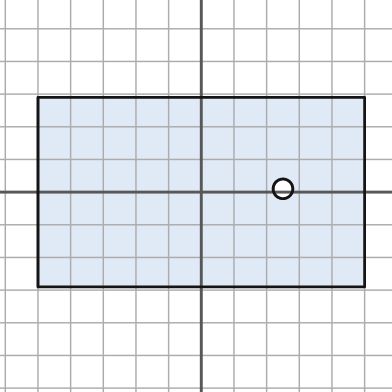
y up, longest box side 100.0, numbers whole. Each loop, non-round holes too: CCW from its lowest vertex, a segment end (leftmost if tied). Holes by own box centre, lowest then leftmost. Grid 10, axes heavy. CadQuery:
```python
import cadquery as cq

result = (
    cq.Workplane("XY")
    .moveTo(-50.0, -29.0)
    .lineTo(50.0, -29.0)
    .lineTo(50.0, 29.0)
    .lineTo(-50.0, 29.0)
    .close()
    .moveTo(25.0, 1.0)
    .circle(3.0)
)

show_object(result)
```